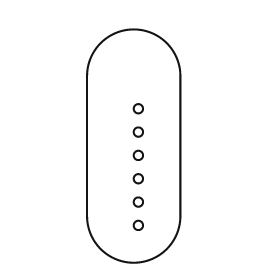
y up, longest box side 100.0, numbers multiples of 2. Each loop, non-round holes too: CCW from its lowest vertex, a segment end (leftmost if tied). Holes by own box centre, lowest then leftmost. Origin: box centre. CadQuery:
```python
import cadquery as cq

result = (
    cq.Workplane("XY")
    .moveTo(-20.0, -30.0)
    .threePointArc((0.0, -50.0), (20.0, -30.0))
    .lineTo(20.0, 30.0)
    .threePointArc((0.0, 50.0), (-20.0, 30.0))
    .close()
    .moveTo(2.0, -34.0)
    .circle(2.0)
    .moveTo(2.0, -24.0)
    .circle(2.0)
    .moveTo(2.0, -14.0)
    .circle(2.0)
    .moveTo(2.0, -4.0)
    .circle(2.0)
    .moveTo(2.0, 6.0)
    .circle(2.0)
    .moveTo(2.0, 16.0)
    .circle(2.0)
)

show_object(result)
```